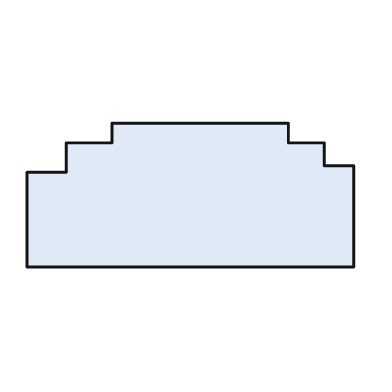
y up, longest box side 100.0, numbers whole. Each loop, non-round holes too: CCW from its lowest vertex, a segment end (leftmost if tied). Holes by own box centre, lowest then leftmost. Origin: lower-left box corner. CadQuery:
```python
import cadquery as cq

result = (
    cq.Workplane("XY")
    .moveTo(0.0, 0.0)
    .lineTo(100.0, 0.0)
    .lineTo(100.0, 31.0)
    .lineTo(91.0, 31.0)
    .lineTo(91.0, 38.0)
    .lineTo(80.0, 38.0)
    .lineTo(80.0, 44.0)
    .lineTo(26.0, 44.0)
    .lineTo(26.0, 38.0)
    .lineTo(12.0, 38.0)
    .lineTo(12.0, 29.0)
    .lineTo(0.0, 29.0)
    .close()
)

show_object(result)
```